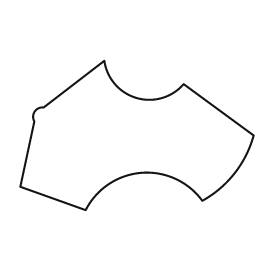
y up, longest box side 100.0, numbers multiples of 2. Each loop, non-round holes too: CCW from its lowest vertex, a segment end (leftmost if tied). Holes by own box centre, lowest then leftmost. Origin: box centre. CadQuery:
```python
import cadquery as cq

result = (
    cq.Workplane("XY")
    .moveTo(-22.0, -32.0)
    .threePointArc((2.0, -16.0), (28.0, -28.0))
    .threePointArc((42.0, -16.0), (50.0, 0.0))
    .lineTo(20.0, 22.0)
    .threePointArc((0.0, 16.0), (-14.0, 32.0))
    .lineTo(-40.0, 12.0)
    .threePointArc((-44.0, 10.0), (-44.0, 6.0))
    .lineTo(-50.0, -22.0)
    .close()
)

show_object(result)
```